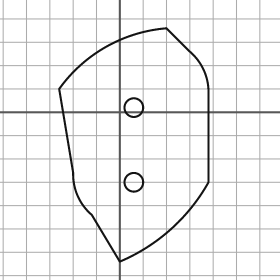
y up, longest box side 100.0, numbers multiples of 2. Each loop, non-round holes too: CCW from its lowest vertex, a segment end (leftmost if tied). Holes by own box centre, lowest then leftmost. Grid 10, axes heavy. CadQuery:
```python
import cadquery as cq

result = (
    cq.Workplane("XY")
    .moveTo(0.0, -64.0)
    .threePointArc((22.0, -50.0), (38.0, -30.0))
    .lineTo(38.0, 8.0)
    .threePointArc((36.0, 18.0), (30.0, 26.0))
    .lineTo(20.0, 36.0)
    .threePointArc((-6.0, 28.0), (-26.0, 10.0))
    .lineTo(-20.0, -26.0)
    .threePointArc((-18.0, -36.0), (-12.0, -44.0))
    .close()
    .moveTo(6.0, -30.0)
    .circle(4.0)
    .moveTo(6.0, 2.0)
    .circle(4.0)
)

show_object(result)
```